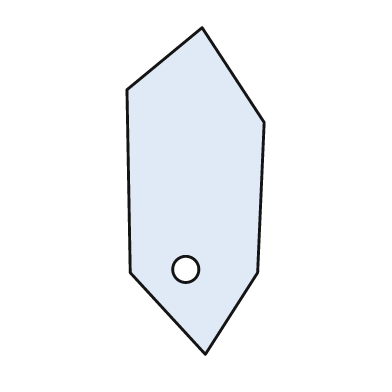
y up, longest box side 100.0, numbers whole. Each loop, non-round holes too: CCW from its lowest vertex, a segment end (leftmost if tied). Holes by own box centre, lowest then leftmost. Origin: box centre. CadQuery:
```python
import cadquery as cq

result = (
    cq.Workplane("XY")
    .moveTo(3.0, -50.0)
    .lineTo(19.0, -25.0)
    .lineTo(21.0, 21.0)
    .lineTo(2.0, 50.0)
    .lineTo(-21.0, 31.0)
    .lineTo(-20.0, -25.0)
    .close()
    .moveTo(-3.0, -24.0)
    .circle(4.0)
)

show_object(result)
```